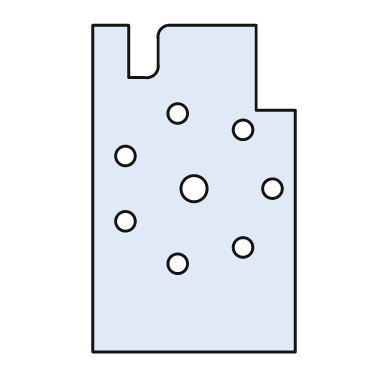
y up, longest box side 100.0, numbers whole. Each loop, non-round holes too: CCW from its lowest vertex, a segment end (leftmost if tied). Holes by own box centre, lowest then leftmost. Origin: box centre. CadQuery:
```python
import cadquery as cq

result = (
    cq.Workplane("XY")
    .moveTo(-31.0, -50.0)
    .lineTo(31.0, -50.0)
    .lineTo(31.0, 24.0)
    .lineTo(19.0, 24.0)
    .lineTo(19.0, 50.0)
    .lineTo(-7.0, 50.0)
    .threePointArc((-10.0, 49.0), (-11.0, 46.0))
    .lineTo(-11.0, 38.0)
    .threePointArc((-12.0, 35.0), (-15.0, 34.0))
    .lineTo(-20.0, 34.0)
    .lineTo(-20.0, 50.0)
    .lineTo(-31.0, 50.0)
    .close()
    .moveTo(-5.0, -23.0)
    .circle(3.0)
    .moveTo(15.0, -18.0)
    .circle(3.0)
    .moveTo(-21.0, -10.0)
    .circle(3.0)
    .moveTo(0.0, 0.0)
    .circle(4.0)
    .moveTo(24.0, 0.0)
    .circle(3.0)
    .moveTo(-21.0, 10.0)
    .circle(3.0)
    .moveTo(15.0, 18.0)
    .circle(3.0)
    .moveTo(-5.0, 23.0)
    .circle(3.0)
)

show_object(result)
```